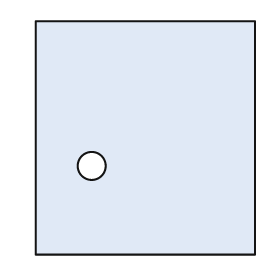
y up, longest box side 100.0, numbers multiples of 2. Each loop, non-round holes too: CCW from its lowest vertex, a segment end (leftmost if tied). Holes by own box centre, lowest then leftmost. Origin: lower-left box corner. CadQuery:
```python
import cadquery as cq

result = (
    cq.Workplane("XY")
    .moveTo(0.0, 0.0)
    .lineTo(94.0, 0.0)
    .lineTo(94.0, 100.0)
    .lineTo(0.0, 100.0)
    .close()
    .moveTo(24.0, 38.0)
    .circle(6.0)
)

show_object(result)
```